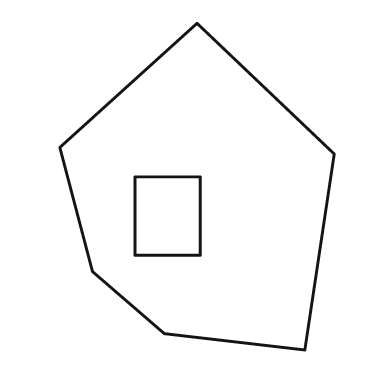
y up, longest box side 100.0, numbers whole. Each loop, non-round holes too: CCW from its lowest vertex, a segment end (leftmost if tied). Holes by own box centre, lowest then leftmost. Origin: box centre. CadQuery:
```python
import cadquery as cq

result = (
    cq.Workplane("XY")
    .moveTo(33.0, -50.0)
    .lineTo(42.0, 10.0)
    .lineTo(0.0, 50.0)
    .lineTo(-42.0, 12.0)
    .lineTo(-32.0, -26.0)
    .lineTo(-10.0, -45.0)
    .close()
    .moveTo(-19.0, -21.0)
    .lineTo(1.0, -21.0)
    .lineTo(1.0, 3.0)
    .lineTo(-19.0, 3.0)
    .close()
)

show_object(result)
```